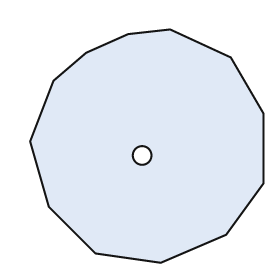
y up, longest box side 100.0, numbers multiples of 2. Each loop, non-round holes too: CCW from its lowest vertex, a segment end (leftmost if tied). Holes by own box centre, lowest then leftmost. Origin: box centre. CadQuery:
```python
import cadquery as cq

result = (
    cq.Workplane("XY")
    .moveTo(6.0, -50.0)
    .lineTo(34.0, -38.0)
    .lineTo(50.0, -16.0)
    .lineTo(50.0, 14.0)
    .lineTo(36.0, 38.0)
    .lineTo(10.0, 50.0)
    .lineTo(-8.0, 48.0)
    .lineTo(-26.0, 40.0)
    .lineTo(-40.0, 28.0)
    .lineTo(-50.0, 2.0)
    .lineTo(-42.0, -26.0)
    .lineTo(-22.0, -46.0)
    .close()
    .moveTo(-2.0, -4.0)
    .circle(4.0)
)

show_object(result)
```